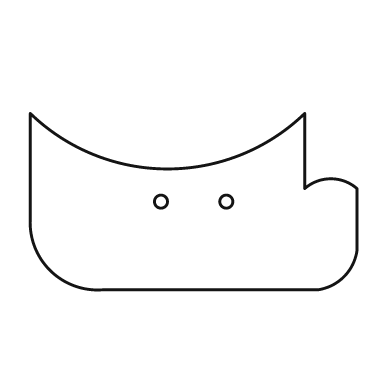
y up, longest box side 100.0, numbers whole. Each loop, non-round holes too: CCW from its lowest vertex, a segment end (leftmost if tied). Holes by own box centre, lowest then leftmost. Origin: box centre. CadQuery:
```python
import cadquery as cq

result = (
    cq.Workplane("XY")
    .moveTo(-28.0, -27.0)
    .lineTo(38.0, -27.0)
    .threePointArc((46.0, -23.0), (50.0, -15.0))
    .lineTo(50.0, 4.0)
    .threePointArc((42.0, 7.0), (34.0, 4.0))
    .lineTo(34.0, 27.0)
    .threePointArc((-8.0, 10.0), (-50.0, 27.0))
    .lineTo(-50.0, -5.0)
    .threePointArc((-44.0, -21.0), (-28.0, -27.0))
    .close()
    .moveTo(-10.0, 0.0)
    .circle(2.0)
    .moveTo(10.0, 0.0)
    .circle(2.0)
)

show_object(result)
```